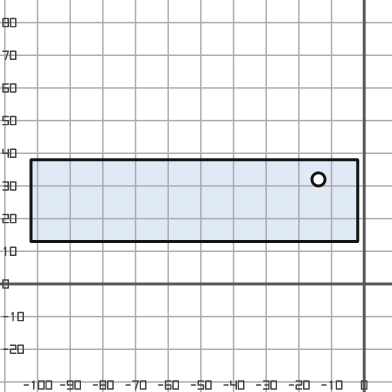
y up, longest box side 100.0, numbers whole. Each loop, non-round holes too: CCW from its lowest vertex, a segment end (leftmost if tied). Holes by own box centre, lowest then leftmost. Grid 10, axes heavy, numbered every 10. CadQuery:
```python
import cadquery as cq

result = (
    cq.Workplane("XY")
    .moveTo(-102.0, 13.0)
    .lineTo(-2.0, 13.0)
    .lineTo(-2.0, 38.0)
    .lineTo(-102.0, 38.0)
    .close()
    .moveTo(-14.0, 32.0)
    .circle(2.0)
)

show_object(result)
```